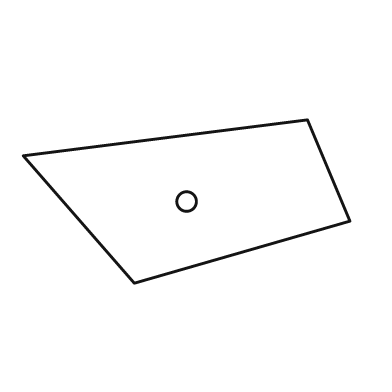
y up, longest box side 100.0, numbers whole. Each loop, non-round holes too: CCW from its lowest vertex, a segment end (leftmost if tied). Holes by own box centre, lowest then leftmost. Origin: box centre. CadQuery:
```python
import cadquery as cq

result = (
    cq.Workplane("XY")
    .moveTo(-16.0, -25.0)
    .lineTo(50.0, -6.0)
    .lineTo(37.0, 25.0)
    .lineTo(-50.0, 14.0)
    .close()
    .moveTo(0.0, 0.0)
    .circle(3.0)
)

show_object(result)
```